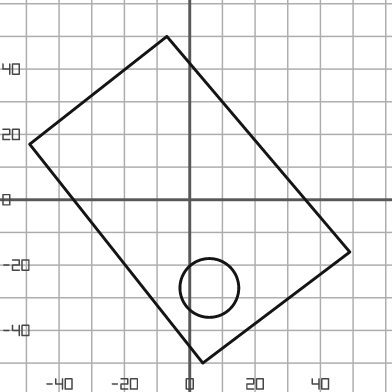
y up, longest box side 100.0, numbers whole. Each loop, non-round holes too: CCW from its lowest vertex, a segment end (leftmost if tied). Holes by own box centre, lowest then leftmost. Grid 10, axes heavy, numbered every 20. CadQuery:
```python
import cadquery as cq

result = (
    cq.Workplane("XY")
    .moveTo(4.0, -50.0)
    .lineTo(49.0, -16.0)
    .lineTo(-7.0, 50.0)
    .lineTo(-49.0, 17.0)
    .close()
    .moveTo(6.0, -27.0)
    .circle(9.0)
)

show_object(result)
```